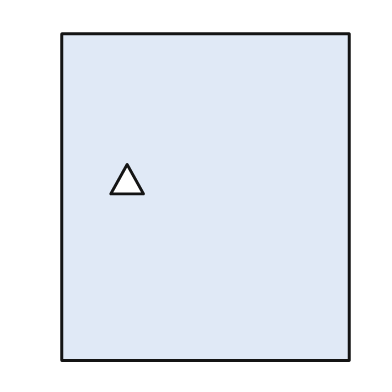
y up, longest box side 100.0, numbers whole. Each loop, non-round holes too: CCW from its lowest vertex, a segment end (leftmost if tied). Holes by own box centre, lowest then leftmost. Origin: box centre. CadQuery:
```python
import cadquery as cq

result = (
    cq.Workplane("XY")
    .moveTo(-44.0, -50.0)
    .lineTo(44.0, -50.0)
    .lineTo(44.0, 50.0)
    .lineTo(-44.0, 50.0)
    .close()
    .moveTo(-29.0, 1.0)
    .lineTo(-19.0, 1.0)
    .lineTo(-24.0, 10.0)
    .close()
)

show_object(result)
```